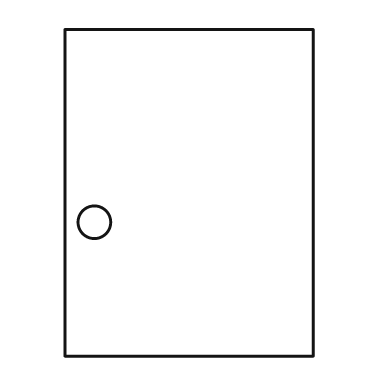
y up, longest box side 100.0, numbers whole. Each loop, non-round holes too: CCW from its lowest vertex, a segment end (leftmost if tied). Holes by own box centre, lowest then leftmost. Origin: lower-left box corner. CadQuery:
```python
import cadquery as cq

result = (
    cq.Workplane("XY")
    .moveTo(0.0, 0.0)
    .lineTo(76.0, 0.0)
    .lineTo(76.0, 100.0)
    .lineTo(0.0, 100.0)
    .close()
    .moveTo(9.0, 41.0)
    .circle(5.0)
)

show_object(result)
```